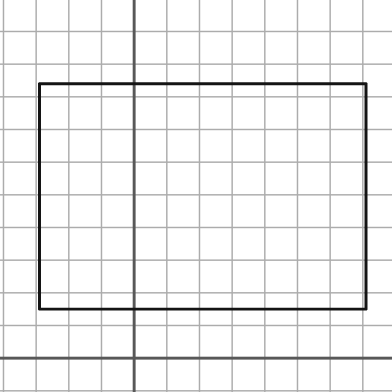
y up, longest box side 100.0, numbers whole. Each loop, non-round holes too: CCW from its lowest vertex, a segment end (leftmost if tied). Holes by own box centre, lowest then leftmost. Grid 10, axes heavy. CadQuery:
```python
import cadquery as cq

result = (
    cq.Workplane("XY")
    .moveTo(-29.0, 15.0)
    .lineTo(71.0, 15.0)
    .lineTo(71.0, 84.0)
    .lineTo(-29.0, 84.0)
    .close()
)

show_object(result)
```